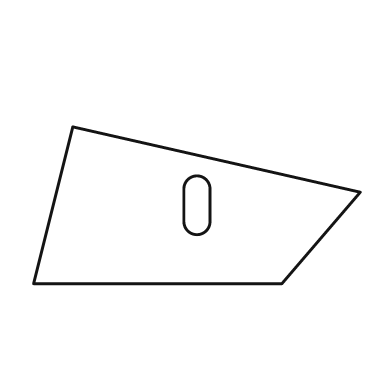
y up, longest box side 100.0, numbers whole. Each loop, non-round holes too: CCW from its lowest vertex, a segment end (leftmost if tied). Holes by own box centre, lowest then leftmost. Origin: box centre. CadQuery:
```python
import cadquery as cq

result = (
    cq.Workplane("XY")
    .moveTo(-50.0, -24.0)
    .lineTo(26.0, -24.0)
    .lineTo(50.0, 4.0)
    .lineTo(-38.0, 24.0)
    .close()
    .moveTo(-4.0, -5.0)
    .threePointArc((0.0, -9.0), (4.0, -5.0))
    .lineTo(4.0, 5.0)
    .threePointArc((0.0, 9.0), (-4.0, 5.0))
    .close()
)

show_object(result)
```